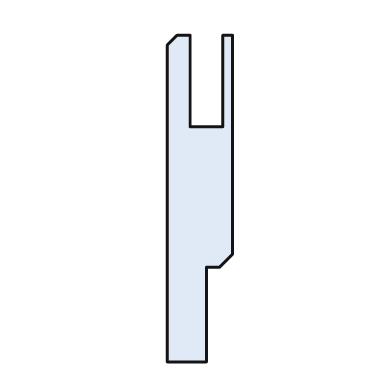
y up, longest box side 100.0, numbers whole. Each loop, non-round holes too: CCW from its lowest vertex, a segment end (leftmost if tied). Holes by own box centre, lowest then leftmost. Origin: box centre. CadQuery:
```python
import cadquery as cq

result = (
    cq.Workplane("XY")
    .moveTo(-10.0, -50.0)
    .lineTo(2.0, -50.0)
    .lineTo(2.0, -21.0)
    .lineTo(6.0, -21.0)
    .lineTo(10.0, -17.0)
    .lineTo(10.0, 50.0)
    .lineTo(7.0, 50.0)
    .lineTo(7.0, 22.0)
    .lineTo(-3.0, 22.0)
    .lineTo(-3.0, 50.0)
    .lineTo(-7.0, 50.0)
    .lineTo(-10.0, 47.0)
    .close()
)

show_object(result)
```